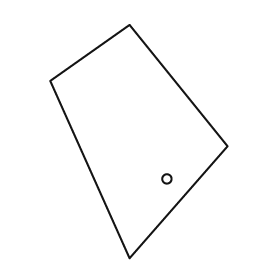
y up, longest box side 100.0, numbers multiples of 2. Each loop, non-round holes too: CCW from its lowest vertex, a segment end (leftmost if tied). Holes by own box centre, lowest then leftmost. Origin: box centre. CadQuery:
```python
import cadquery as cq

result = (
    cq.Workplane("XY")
    .moveTo(-4.0, -50.0)
    .lineTo(38.0, -2.0)
    .lineTo(-4.0, 50.0)
    .lineTo(-38.0, 26.0)
    .close()
    .moveTo(12.0, -16.0)
    .circle(2.0)
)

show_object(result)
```